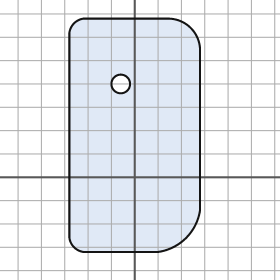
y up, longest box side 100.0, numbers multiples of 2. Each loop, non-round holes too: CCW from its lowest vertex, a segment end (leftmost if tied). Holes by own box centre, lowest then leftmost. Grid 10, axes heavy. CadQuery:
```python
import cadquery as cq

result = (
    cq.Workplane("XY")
    .moveTo(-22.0, -32.0)
    .lineTo(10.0, -32.0)
    .threePointArc((22.0, -26.0), (28.0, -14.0))
    .lineTo(28.0, 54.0)
    .threePointArc((24.0, 64.0), (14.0, 68.0))
    .lineTo(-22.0, 68.0)
    .threePointArc((-26.0, 66.0), (-28.0, 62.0))
    .lineTo(-28.0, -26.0)
    .threePointArc((-26.0, -30.0), (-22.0, -32.0))
    .close()
    .moveTo(-6.0, 40.0)
    .circle(4.0)
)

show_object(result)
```